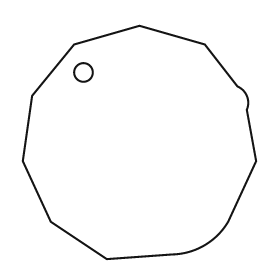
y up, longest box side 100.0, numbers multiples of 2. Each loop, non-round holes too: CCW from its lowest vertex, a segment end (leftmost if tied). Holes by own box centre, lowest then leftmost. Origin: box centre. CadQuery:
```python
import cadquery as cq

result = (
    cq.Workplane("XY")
    .moveTo(-14.0, -50.0)
    .lineTo(14.0, -48.0)
    .threePointArc((28.0, -44.0), (38.0, -34.0))
    .lineTo(50.0, -8.0)
    .lineTo(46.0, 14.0)
    .threePointArc((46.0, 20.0), (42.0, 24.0))
    .lineTo(28.0, 42.0)
    .lineTo(0.0, 50.0)
    .lineTo(-28.0, 42.0)
    .lineTo(-46.0, 20.0)
    .lineTo(-50.0, -8.0)
    .lineTo(-38.0, -34.0)
    .close()
    .moveTo(-24.0, 30.0)
    .circle(4.0)
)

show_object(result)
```